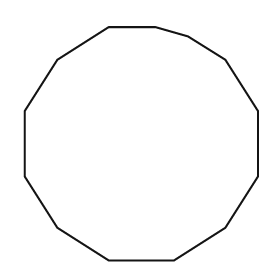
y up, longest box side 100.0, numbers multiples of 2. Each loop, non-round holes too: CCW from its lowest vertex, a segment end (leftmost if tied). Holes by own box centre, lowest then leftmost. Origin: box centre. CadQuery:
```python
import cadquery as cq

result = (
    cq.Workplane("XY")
    .moveTo(-14.0, -50.0)
    .lineTo(14.0, -50.0)
    .lineTo(36.0, -36.0)
    .lineTo(50.0, -14.0)
    .lineTo(50.0, 14.0)
    .lineTo(36.0, 36.0)
    .lineTo(20.0, 46.0)
    .lineTo(6.0, 50.0)
    .lineTo(-14.0, 50.0)
    .lineTo(-36.0, 36.0)
    .lineTo(-50.0, 14.0)
    .lineTo(-50.0, -14.0)
    .lineTo(-36.0, -36.0)
    .close()
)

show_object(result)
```